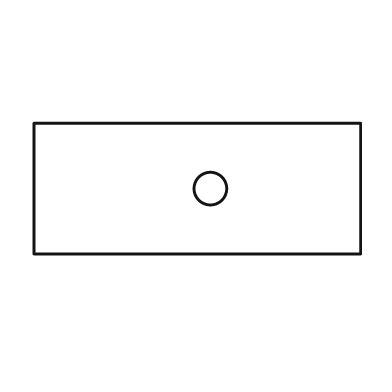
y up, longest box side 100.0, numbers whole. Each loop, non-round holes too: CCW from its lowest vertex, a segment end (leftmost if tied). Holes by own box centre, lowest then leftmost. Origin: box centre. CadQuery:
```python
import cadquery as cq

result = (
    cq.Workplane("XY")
    .moveTo(-50.0, -20.0)
    .lineTo(50.0, -20.0)
    .lineTo(50.0, 20.0)
    .lineTo(-50.0, 20.0)
    .close()
    .moveTo(4.0, 0.0)
    .circle(5.0)
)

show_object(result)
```